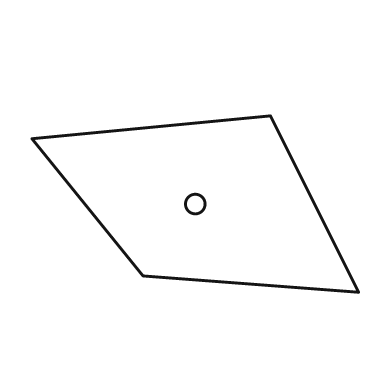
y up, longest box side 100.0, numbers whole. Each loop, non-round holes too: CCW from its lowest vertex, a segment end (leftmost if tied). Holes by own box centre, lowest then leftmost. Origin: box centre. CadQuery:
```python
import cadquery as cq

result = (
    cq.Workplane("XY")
    .moveTo(50.0, -27.0)
    .lineTo(23.0, 27.0)
    .lineTo(-50.0, 20.0)
    .lineTo(-16.0, -22.0)
    .close()
    .moveTo(0.0, 0.0)
    .circle(3.0)
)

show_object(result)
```